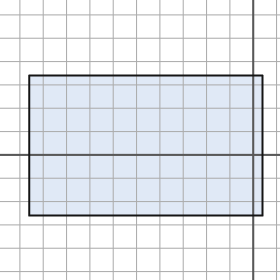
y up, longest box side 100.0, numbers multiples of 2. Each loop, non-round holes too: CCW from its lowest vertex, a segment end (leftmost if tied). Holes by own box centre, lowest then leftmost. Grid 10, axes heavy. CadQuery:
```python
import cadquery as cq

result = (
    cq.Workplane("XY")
    .moveTo(-96.0, -26.0)
    .lineTo(4.0, -26.0)
    .lineTo(4.0, 34.0)
    .lineTo(-96.0, 34.0)
    .close()
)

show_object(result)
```